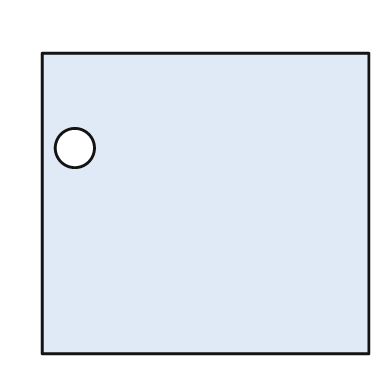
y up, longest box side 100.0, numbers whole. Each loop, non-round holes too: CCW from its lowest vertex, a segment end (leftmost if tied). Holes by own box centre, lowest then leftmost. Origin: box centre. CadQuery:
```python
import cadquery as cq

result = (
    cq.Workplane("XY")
    .moveTo(-50.0, -46.0)
    .lineTo(50.0, -46.0)
    .lineTo(50.0, 46.0)
    .lineTo(-50.0, 46.0)
    .close()
    .moveTo(-40.0, 17.0)
    .circle(6.0)
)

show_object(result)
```